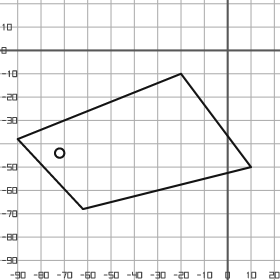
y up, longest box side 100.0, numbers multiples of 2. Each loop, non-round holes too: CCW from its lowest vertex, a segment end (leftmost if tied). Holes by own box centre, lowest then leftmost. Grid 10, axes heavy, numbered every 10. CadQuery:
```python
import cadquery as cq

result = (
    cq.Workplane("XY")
    .moveTo(-62.0, -68.0)
    .lineTo(10.0, -50.0)
    .lineTo(-20.0, -10.0)
    .lineTo(-90.0, -38.0)
    .close()
    .moveTo(-72.0, -44.0)
    .circle(2.0)
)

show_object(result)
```